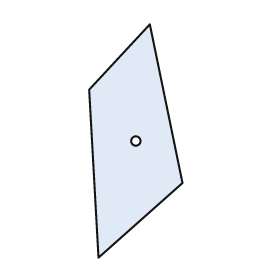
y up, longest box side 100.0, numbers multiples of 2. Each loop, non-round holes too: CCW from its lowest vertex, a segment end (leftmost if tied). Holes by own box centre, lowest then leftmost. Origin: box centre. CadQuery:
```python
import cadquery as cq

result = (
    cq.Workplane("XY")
    .moveTo(-16.0, -50.0)
    .lineTo(20.0, -18.0)
    .lineTo(6.0, 50.0)
    .lineTo(-20.0, 22.0)
    .close()
    .moveTo(0.0, 0.0)
    .circle(2.0)
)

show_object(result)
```